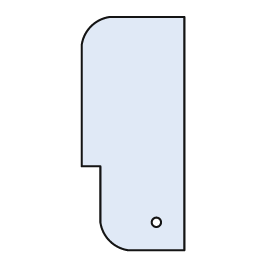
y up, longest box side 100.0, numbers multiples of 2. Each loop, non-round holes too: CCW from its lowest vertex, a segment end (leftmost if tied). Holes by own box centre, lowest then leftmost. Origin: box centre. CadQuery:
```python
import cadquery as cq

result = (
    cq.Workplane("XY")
    .moveTo(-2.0, -50.0)
    .lineTo(22.0, -50.0)
    .lineTo(22.0, 50.0)
    .lineTo(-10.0, 50.0)
    .threePointArc((-18.0, 46.0), (-22.0, 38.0))
    .lineTo(-22.0, -14.0)
    .lineTo(-14.0, -14.0)
    .lineTo(-14.0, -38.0)
    .threePointArc((-10.0, -46.0), (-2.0, -50.0))
    .close()
    .moveTo(10.0, -38.0)
    .circle(2.0)
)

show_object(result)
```